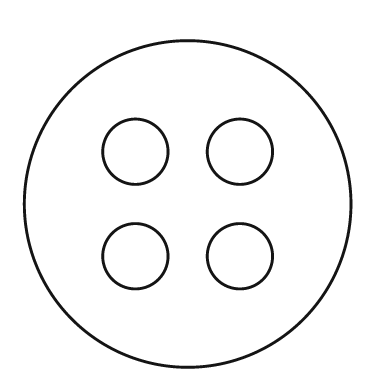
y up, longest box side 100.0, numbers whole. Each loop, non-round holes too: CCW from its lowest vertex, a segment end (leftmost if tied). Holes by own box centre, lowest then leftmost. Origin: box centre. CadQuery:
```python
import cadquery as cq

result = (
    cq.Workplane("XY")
    .moveTo(0.0, 0.0)
    .circle(50.0)
    .moveTo(-16.0, -16.0)
    .circle(10.0)
    .moveTo(16.0, -16.0)
    .circle(10.0)
    .moveTo(-16.0, 16.0)
    .circle(10.0)
    .moveTo(16.0, 16.0)
    .circle(10.0)
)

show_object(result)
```